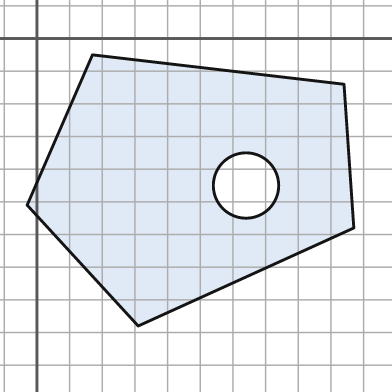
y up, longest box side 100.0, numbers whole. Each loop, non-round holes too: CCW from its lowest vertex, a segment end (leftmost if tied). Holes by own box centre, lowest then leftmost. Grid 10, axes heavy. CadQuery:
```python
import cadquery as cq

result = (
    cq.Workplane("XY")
    .moveTo(31.0, -88.0)
    .lineTo(97.0, -58.0)
    .lineTo(94.0, -14.0)
    .lineTo(17.0, -5.0)
    .lineTo(-3.0, -51.0)
    .close()
    .moveTo(64.0, -45.0)
    .circle(10.0)
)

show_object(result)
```